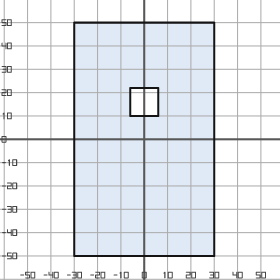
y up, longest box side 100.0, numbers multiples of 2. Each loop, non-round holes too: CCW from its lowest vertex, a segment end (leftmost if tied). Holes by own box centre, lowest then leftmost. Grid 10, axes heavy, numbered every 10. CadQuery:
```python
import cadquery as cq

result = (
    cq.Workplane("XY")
    .moveTo(-30.0, -50.0)
    .lineTo(30.0, -50.0)
    .lineTo(30.0, 50.0)
    .lineTo(-30.0, 50.0)
    .close()
    .moveTo(-6.0, 10.0)
    .lineTo(6.0, 10.0)
    .lineTo(6.0, 22.0)
    .lineTo(-6.0, 22.0)
    .close()
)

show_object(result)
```